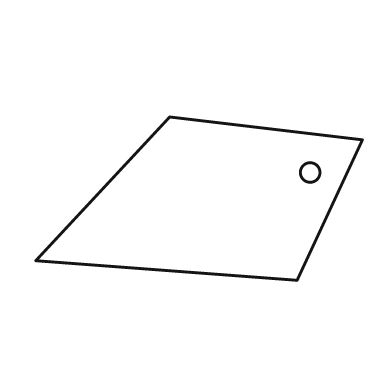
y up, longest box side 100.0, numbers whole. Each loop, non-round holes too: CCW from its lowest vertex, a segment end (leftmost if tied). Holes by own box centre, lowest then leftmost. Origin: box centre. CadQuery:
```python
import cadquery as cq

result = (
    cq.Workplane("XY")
    .moveTo(30.0, -25.0)
    .lineTo(50.0, 18.0)
    .lineTo(-9.0, 25.0)
    .lineTo(-50.0, -19.0)
    .close()
    .moveTo(34.0, 8.0)
    .circle(3.0)
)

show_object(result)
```